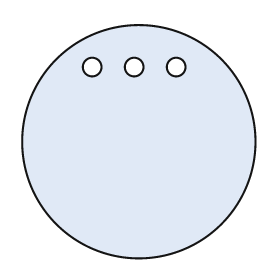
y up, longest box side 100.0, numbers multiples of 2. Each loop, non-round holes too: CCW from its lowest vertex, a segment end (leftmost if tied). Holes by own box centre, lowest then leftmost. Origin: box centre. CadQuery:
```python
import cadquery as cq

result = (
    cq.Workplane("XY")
    .moveTo(0.0, 0.0)
    .circle(50.0)
    .moveTo(-20.0, 32.0)
    .circle(4.0)
    .moveTo(-2.0, 32.0)
    .circle(4.0)
    .moveTo(16.0, 32.0)
    .circle(4.0)
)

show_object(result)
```